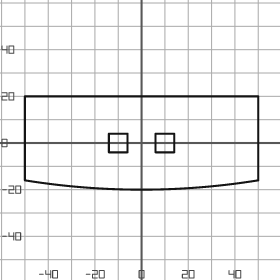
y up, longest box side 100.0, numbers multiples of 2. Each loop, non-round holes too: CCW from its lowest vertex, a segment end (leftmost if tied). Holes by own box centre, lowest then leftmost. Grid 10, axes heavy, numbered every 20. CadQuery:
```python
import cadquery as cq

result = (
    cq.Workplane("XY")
    .moveTo(-50.0, -16.0)
    .threePointArc((0.0, -20.0), (50.0, -16.0))
    .lineTo(50.0, 20.0)
    .lineTo(-50.0, 20.0)
    .close()
    .moveTo(-14.0, -4.0)
    .lineTo(-6.0, -4.0)
    .lineTo(-6.0, 4.0)
    .lineTo(-14.0, 4.0)
    .close()
    .moveTo(6.0, -4.0)
    .lineTo(14.0, -4.0)
    .lineTo(14.0, 4.0)
    .lineTo(6.0, 4.0)
    .close()
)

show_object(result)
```